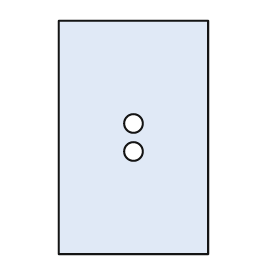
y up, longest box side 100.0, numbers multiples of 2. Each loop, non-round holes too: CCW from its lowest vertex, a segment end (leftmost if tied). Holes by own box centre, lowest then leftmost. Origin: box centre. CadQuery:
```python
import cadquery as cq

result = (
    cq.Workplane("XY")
    .moveTo(-32.0, -50.0)
    .lineTo(32.0, -50.0)
    .lineTo(32.0, 50.0)
    .lineTo(-32.0, 50.0)
    .close()
    .moveTo(0.0, -6.0)
    .circle(4.0)
    .moveTo(0.0, 6.0)
    .circle(4.0)
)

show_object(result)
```